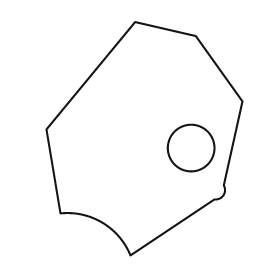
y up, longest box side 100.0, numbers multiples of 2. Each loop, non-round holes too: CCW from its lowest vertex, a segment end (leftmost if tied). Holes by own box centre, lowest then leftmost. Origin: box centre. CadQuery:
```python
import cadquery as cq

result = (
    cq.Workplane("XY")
    .moveTo(-6.0, -50.0)
    .lineTo(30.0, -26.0)
    .threePointArc((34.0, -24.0), (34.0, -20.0))
    .lineTo(42.0, 16.0)
    .lineTo(22.0, 44.0)
    .lineTo(-4.0, 50.0)
    .lineTo(-42.0, 4.0)
    .lineTo(-36.0, -32.0)
    .threePointArc((-18.0, -36.0), (-6.0, -50.0))
    .close()
    .moveTo(20.0, -4.0)
    .circle(10.0)
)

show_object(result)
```